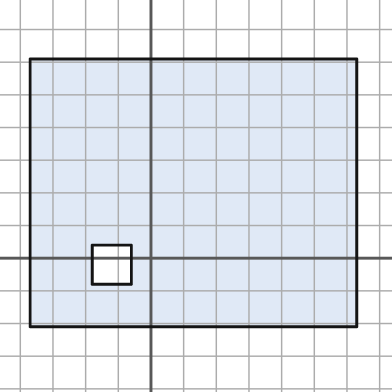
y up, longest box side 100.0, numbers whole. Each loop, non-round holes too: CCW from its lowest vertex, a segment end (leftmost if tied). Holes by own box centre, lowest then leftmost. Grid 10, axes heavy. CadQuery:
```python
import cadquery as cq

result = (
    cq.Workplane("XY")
    .moveTo(-37.0, -21.0)
    .lineTo(63.0, -21.0)
    .lineTo(63.0, 61.0)
    .lineTo(-37.0, 61.0)
    .close()
    .moveTo(-18.0, -8.0)
    .lineTo(-6.0, -8.0)
    .lineTo(-6.0, 4.0)
    .lineTo(-18.0, 4.0)
    .close()
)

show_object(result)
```